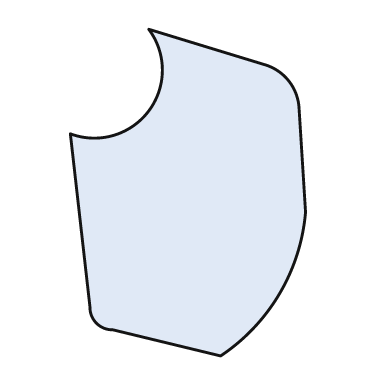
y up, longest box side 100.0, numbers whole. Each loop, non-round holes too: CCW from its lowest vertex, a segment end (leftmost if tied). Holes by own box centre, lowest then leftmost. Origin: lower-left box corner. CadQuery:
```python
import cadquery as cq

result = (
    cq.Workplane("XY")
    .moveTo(46.0, 0.0)
    .threePointArc((64.0, 19.0), (72.0, 44.0))
    .lineTo(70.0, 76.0)
    .threePointArc((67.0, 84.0), (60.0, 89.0))
    .lineTo(24.0, 100.0)
    .threePointArc((24.0, 75.0), (0.0, 68.0))
    .lineTo(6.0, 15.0)
    .threePointArc((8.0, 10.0), (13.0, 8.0))
    .close()
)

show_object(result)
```